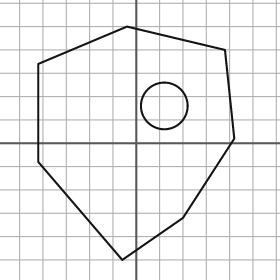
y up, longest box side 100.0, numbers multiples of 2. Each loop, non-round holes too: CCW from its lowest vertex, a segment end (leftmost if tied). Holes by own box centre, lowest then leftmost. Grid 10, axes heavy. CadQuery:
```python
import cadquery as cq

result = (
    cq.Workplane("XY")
    .moveTo(-6.0, -50.0)
    .lineTo(20.0, -32.0)
    .lineTo(42.0, 2.0)
    .lineTo(38.0, 40.0)
    .lineTo(-4.0, 50.0)
    .lineTo(-42.0, 34.0)
    .lineTo(-42.0, -8.0)
    .close()
    .moveTo(12.0, 16.0)
    .circle(10.0)
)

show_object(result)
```